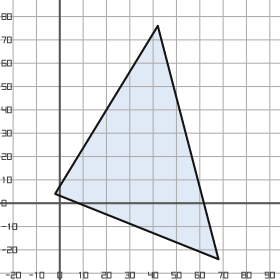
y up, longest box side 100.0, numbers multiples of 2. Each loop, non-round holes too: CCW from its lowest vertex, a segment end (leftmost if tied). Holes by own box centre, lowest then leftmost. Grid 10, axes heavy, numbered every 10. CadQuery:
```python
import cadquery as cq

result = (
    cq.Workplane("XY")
    .moveTo(68.0, -24.0)
    .lineTo(42.0, 76.0)
    .lineTo(-2.0, 4.0)
    .close()
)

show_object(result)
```